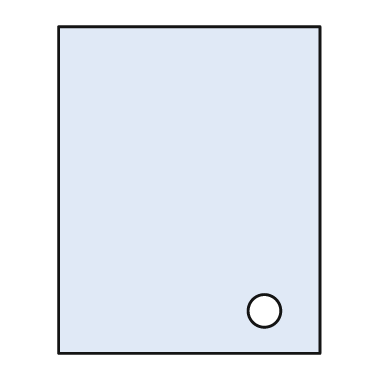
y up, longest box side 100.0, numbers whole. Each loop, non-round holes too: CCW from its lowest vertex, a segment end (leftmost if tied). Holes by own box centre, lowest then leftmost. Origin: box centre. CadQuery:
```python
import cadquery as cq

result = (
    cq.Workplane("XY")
    .moveTo(-40.0, -50.0)
    .lineTo(40.0, -50.0)
    .lineTo(40.0, 50.0)
    .lineTo(-40.0, 50.0)
    .close()
    .moveTo(23.0, -37.0)
    .circle(5.0)
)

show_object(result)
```